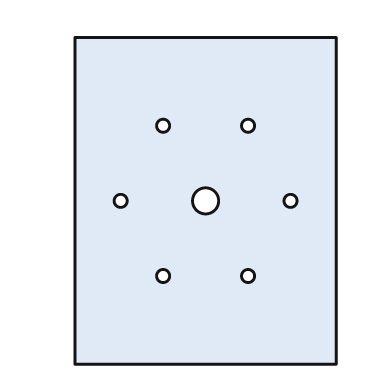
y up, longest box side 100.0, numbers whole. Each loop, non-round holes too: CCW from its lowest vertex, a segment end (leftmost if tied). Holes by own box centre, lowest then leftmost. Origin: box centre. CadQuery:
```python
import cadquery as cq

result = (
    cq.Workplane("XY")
    .moveTo(-40.0, -50.0)
    .lineTo(40.0, -50.0)
    .lineTo(40.0, 50.0)
    .lineTo(-40.0, 50.0)
    .close()
    .moveTo(-13.0, -23.0)
    .circle(2.0)
    .moveTo(13.0, -23.0)
    .circle(2.0)
    .moveTo(-26.0, 0.0)
    .circle(2.0)
    .moveTo(0.0, 0.0)
    .circle(4.0)
    .moveTo(26.0, 0.0)
    .circle(2.0)
    .moveTo(-13.0, 23.0)
    .circle(2.0)
    .moveTo(13.0, 23.0)
    .circle(2.0)
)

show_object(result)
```